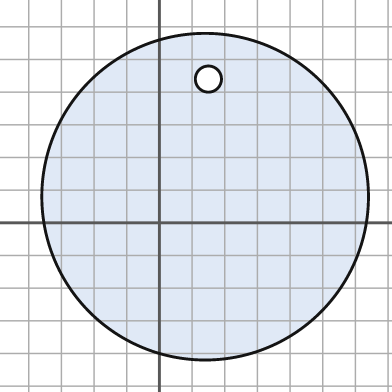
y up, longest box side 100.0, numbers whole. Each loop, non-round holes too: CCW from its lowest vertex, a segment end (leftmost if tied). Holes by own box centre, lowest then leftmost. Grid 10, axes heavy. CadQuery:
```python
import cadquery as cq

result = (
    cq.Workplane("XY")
    .moveTo(14.0, 8.0)
    .circle(50.0)
    .moveTo(15.0, 44.0)
    .circle(4.0)
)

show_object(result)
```